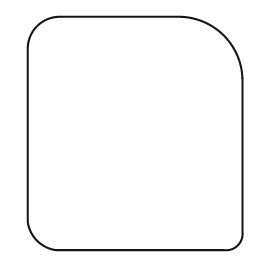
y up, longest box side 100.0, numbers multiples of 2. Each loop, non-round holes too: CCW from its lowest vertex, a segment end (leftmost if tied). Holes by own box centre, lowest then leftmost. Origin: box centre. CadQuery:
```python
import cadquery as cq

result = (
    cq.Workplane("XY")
    .moveTo(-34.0, -50.0)
    .lineTo(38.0, -50.0)
    .threePointArc((44.0, -48.0), (46.0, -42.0))
    .lineTo(46.0, 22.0)
    .threePointArc((38.0, 42.0), (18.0, 50.0))
    .lineTo(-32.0, 50.0)
    .threePointArc((-42.0, 46.0), (-46.0, 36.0))
    .lineTo(-46.0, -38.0)
    .threePointArc((-42.0, -46.0), (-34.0, -50.0))
    .close()
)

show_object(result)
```